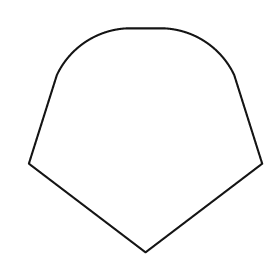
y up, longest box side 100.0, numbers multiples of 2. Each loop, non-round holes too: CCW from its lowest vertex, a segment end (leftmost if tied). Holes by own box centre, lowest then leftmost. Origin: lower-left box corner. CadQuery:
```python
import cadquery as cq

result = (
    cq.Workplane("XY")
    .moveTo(50.0, 0.0)
    .lineTo(100.0, 38.0)
    .lineTo(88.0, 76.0)
    .threePointArc((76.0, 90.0), (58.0, 96.0))
    .lineTo(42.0, 96.0)
    .threePointArc((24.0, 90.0), (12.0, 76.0))
    .lineTo(0.0, 38.0)
    .close()
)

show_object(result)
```